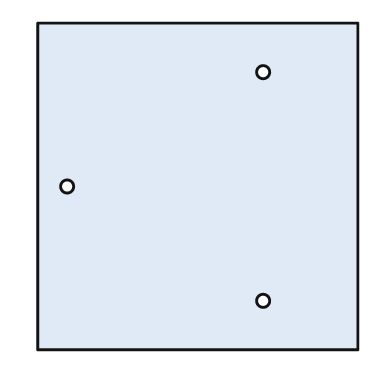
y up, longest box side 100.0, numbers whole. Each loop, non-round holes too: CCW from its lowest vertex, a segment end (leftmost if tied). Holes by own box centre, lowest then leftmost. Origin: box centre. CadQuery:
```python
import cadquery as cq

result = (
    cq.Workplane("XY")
    .moveTo(-49.0, -50.0)
    .lineTo(49.0, -50.0)
    .lineTo(49.0, 50.0)
    .lineTo(-49.0, 50.0)
    .close()
    .moveTo(20.0, -35.0)
    .circle(2.0)
    .moveTo(-40.0, 0.0)
    .circle(2.0)
    .moveTo(20.0, 35.0)
    .circle(2.0)
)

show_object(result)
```